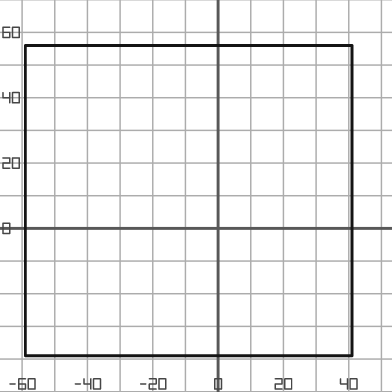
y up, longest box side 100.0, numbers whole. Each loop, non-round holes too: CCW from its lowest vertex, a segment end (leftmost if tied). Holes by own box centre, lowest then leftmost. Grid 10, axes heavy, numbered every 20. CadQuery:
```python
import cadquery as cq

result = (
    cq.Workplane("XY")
    .moveTo(-59.0, -39.0)
    .lineTo(41.0, -39.0)
    .lineTo(41.0, 56.0)
    .lineTo(-59.0, 56.0)
    .close()
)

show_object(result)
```